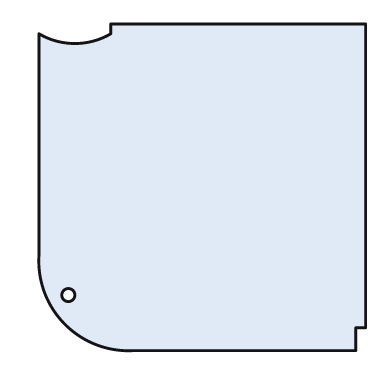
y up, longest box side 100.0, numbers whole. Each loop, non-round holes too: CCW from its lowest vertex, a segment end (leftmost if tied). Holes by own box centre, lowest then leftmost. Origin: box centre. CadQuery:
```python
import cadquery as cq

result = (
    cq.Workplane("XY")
    .moveTo(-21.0, -50.0)
    .lineTo(47.0, -50.0)
    .lineTo(47.0, -43.0)
    .lineTo(50.0, -43.0)
    .lineTo(50.0, 50.0)
    .lineTo(-28.0, 50.0)
    .lineTo(-28.0, 47.0)
    .threePointArc((-39.0, 44.0), (-50.0, 47.0))
    .lineTo(-50.0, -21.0)
    .threePointArc((-42.0, -42.0), (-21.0, -50.0))
    .close()
    .moveTo(-41.0, -33.0)
    .circle(2.0)
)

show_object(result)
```